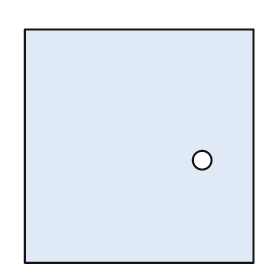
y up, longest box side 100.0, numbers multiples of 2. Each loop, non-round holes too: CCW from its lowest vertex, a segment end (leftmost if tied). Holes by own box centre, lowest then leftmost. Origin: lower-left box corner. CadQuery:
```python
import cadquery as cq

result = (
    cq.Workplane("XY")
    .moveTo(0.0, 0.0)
    .lineTo(98.0, 0.0)
    .lineTo(98.0, 100.0)
    .lineTo(0.0, 100.0)
    .close()
    .moveTo(76.0, 44.0)
    .circle(4.0)
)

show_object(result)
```